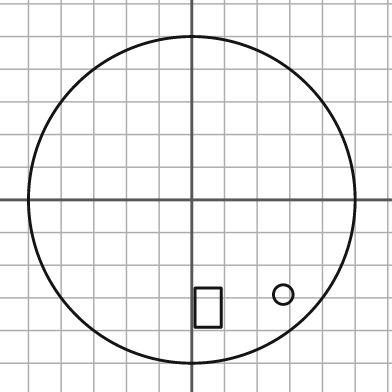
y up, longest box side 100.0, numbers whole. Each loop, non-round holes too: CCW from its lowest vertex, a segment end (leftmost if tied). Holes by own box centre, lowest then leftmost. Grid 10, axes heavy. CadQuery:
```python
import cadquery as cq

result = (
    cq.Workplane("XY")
    .moveTo(0.0, 0.0)
    .circle(50.0)
    .moveTo(1.0, -39.0)
    .lineTo(9.0, -39.0)
    .lineTo(9.0, -27.0)
    .lineTo(1.0, -27.0)
    .close()
    .moveTo(28.0, -29.0)
    .circle(3.0)
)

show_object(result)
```